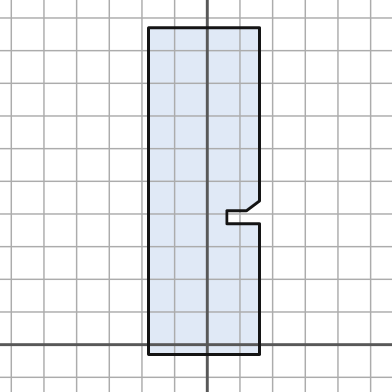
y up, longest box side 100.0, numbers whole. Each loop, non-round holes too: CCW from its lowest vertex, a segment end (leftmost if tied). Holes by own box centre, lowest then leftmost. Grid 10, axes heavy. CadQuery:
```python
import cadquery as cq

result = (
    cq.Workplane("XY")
    .moveTo(-18.0, -3.0)
    .lineTo(16.0, -3.0)
    .lineTo(16.0, 37.0)
    .lineTo(6.0, 37.0)
    .lineTo(6.0, 41.0)
    .lineTo(12.0, 41.0)
    .lineTo(16.0, 44.0)
    .lineTo(16.0, 97.0)
    .lineTo(-18.0, 97.0)
    .close()
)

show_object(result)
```